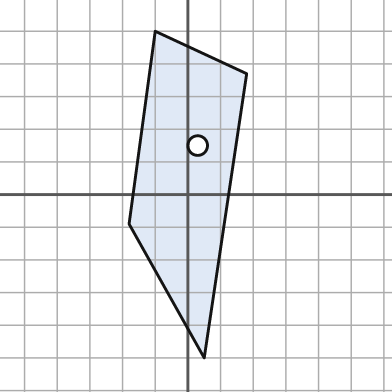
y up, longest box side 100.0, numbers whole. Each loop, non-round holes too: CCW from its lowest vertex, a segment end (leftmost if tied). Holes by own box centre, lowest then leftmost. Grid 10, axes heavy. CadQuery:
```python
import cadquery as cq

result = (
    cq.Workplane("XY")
    .moveTo(5.0, -50.0)
    .lineTo(18.0, 37.0)
    .lineTo(-10.0, 50.0)
    .lineTo(-18.0, -9.0)
    .close()
    .moveTo(3.0, 15.0)
    .circle(3.0)
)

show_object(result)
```